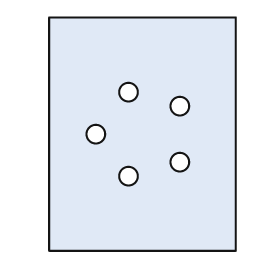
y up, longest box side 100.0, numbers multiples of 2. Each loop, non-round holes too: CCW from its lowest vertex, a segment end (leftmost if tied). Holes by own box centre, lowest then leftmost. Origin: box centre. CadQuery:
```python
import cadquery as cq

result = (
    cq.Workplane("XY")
    .moveTo(-40.0, -50.0)
    .lineTo(40.0, -50.0)
    .lineTo(40.0, 50.0)
    .lineTo(-40.0, 50.0)
    .close()
    .moveTo(-6.0, -18.0)
    .circle(4.0)
    .moveTo(16.0, -12.0)
    .circle(4.0)
    .moveTo(-20.0, 0.0)
    .circle(4.0)
    .moveTo(16.0, 12.0)
    .circle(4.0)
    .moveTo(-6.0, 18.0)
    .circle(4.0)
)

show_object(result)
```